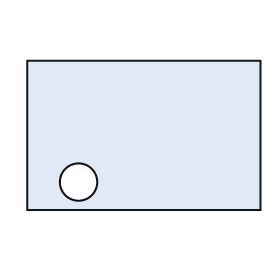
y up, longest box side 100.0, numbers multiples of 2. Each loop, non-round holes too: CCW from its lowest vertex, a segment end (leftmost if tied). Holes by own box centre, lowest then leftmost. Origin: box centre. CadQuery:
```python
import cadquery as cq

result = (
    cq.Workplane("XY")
    .moveTo(-50.0, -32.0)
    .lineTo(50.0, -32.0)
    .lineTo(50.0, 32.0)
    .lineTo(-50.0, 32.0)
    .close()
    .moveTo(-28.0, -20.0)
    .circle(8.0)
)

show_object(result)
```